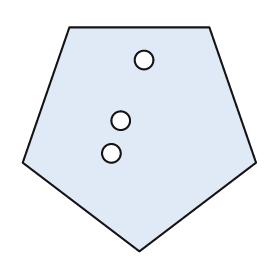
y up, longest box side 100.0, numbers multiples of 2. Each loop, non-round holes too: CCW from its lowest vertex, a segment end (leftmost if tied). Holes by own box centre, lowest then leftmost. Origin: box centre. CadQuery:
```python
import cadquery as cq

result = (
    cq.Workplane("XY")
    .moveTo(0.0, -48.0)
    .lineTo(50.0, -10.0)
    .lineTo(30.0, 48.0)
    .lineTo(-30.0, 48.0)
    .lineTo(-50.0, -10.0)
    .close()
    .moveTo(-12.0, -6.0)
    .circle(4.0)
    .moveTo(-8.0, 8.0)
    .circle(4.0)
    .moveTo(2.0, 34.0)
    .circle(4.0)
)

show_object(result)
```